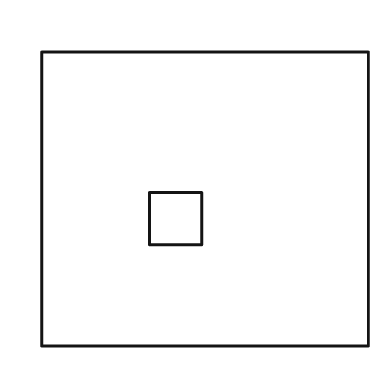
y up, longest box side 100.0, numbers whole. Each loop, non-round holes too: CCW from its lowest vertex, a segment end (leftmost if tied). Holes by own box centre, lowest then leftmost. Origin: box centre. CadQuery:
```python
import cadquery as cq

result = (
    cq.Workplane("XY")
    .moveTo(-50.0, -45.0)
    .lineTo(50.0, -45.0)
    .lineTo(50.0, 45.0)
    .lineTo(-50.0, 45.0)
    .close()
    .moveTo(-17.0, -14.0)
    .lineTo(-1.0, -14.0)
    .lineTo(-1.0, 2.0)
    .lineTo(-17.0, 2.0)
    .close()
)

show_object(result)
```